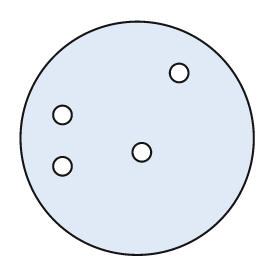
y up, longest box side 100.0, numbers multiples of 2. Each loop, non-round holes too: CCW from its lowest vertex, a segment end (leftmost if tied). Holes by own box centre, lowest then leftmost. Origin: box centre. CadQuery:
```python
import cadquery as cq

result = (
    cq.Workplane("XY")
    .moveTo(0.0, 0.0)
    .circle(50.0)
    .moveTo(-32.0, -12.0)
    .circle(4.0)
    .moveTo(2.0, -6.0)
    .circle(4.0)
    .moveTo(-32.0, 10.0)
    .circle(4.0)
    .moveTo(18.0, 28.0)
    .circle(4.0)
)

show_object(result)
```